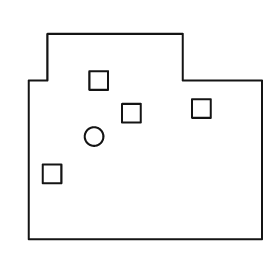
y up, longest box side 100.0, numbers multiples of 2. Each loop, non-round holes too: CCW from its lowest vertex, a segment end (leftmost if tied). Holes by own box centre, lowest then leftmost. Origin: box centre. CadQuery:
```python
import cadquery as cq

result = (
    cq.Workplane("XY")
    .moveTo(-50.0, -44.0)
    .lineTo(50.0, -44.0)
    .lineTo(50.0, 24.0)
    .lineTo(16.0, 24.0)
    .lineTo(16.0, 44.0)
    .lineTo(-42.0, 44.0)
    .lineTo(-42.0, 24.0)
    .lineTo(-50.0, 24.0)
    .close()
    .moveTo(-44.0, -20.0)
    .lineTo(-36.0, -20.0)
    .lineTo(-36.0, -12.0)
    .lineTo(-44.0, -12.0)
    .close()
    .moveTo(-22.0, 0.0)
    .circle(4.0)
    .moveTo(-10.0, 6.0)
    .lineTo(-2.0, 6.0)
    .lineTo(-2.0, 14.0)
    .lineTo(-10.0, 14.0)
    .close()
    .moveTo(20.0, 8.0)
    .lineTo(28.0, 8.0)
    .lineTo(28.0, 16.0)
    .lineTo(20.0, 16.0)
    .close()
    .moveTo(-24.0, 20.0)
    .lineTo(-16.0, 20.0)
    .lineTo(-16.0, 28.0)
    .lineTo(-24.0, 28.0)
    .close()
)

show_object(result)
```